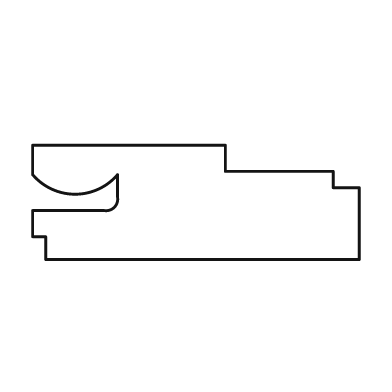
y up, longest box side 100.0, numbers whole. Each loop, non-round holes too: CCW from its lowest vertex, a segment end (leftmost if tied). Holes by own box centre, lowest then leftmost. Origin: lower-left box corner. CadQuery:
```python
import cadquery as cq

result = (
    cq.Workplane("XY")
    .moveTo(4.0, 0.0)
    .lineTo(100.0, 0.0)
    .lineTo(100.0, 22.0)
    .lineTo(92.0, 22.0)
    .lineTo(92.0, 27.0)
    .lineTo(59.0, 27.0)
    .lineTo(59.0, 35.0)
    .lineTo(0.0, 35.0)
    .lineTo(0.0, 26.0)
    .threePointArc((13.0, 20.0), (26.0, 26.0))
    .lineTo(26.0, 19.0)
    .threePointArc((25.0, 16.0), (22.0, 15.0))
    .lineTo(0.0, 15.0)
    .lineTo(0.0, 7.0)
    .lineTo(4.0, 7.0)
    .close()
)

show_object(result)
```